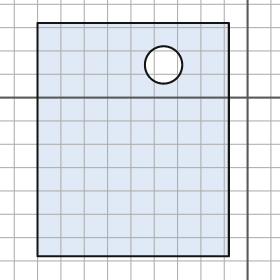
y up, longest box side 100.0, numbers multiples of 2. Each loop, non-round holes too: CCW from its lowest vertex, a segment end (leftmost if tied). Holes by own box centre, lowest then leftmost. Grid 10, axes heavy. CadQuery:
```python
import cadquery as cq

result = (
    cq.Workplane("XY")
    .moveTo(-90.0, -68.0)
    .lineTo(-8.0, -68.0)
    .lineTo(-8.0, 32.0)
    .lineTo(-90.0, 32.0)
    .close()
    .moveTo(-36.0, 14.0)
    .circle(8.0)
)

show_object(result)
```